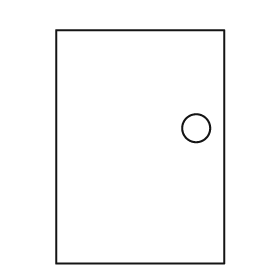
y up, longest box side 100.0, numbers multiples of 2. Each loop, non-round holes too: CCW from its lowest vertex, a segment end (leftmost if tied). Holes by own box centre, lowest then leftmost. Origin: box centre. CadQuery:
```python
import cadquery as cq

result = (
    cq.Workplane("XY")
    .moveTo(-36.0, -50.0)
    .lineTo(36.0, -50.0)
    .lineTo(36.0, 50.0)
    .lineTo(-36.0, 50.0)
    .close()
    .moveTo(24.0, 8.0)
    .circle(6.0)
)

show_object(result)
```